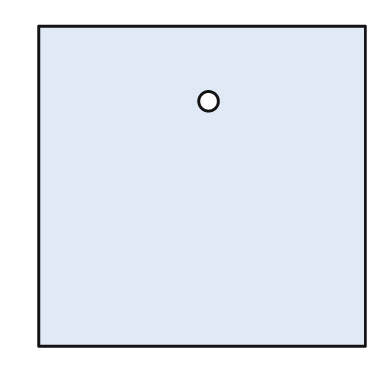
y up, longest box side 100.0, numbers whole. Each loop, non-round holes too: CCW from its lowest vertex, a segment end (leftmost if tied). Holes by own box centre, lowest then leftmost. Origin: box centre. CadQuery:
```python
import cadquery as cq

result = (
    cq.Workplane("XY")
    .moveTo(-50.0, -49.0)
    .lineTo(50.0, -49.0)
    .lineTo(50.0, 49.0)
    .lineTo(-50.0, 49.0)
    .close()
    .moveTo(2.0, 26.0)
    .circle(3.0)
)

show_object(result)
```